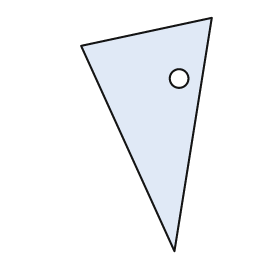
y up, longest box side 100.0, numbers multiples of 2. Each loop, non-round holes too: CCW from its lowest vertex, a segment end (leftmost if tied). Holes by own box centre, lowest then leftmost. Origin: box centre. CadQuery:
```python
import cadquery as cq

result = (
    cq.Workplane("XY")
    .moveTo(12.0, -50.0)
    .lineTo(28.0, 50.0)
    .lineTo(-28.0, 38.0)
    .close()
    .moveTo(14.0, 24.0)
    .circle(4.0)
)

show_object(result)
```